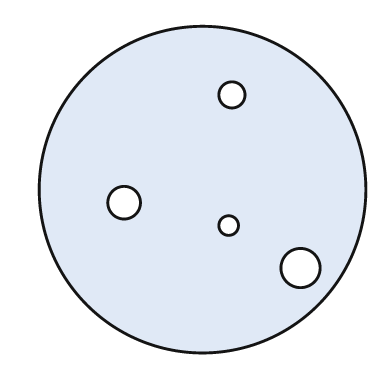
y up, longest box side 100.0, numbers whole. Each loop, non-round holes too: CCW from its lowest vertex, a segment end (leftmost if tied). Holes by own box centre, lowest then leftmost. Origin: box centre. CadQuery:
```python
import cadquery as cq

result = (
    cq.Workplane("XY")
    .moveTo(0.0, 0.0)
    .circle(50.0)
    .moveTo(30.0, -24.0)
    .circle(6.0)
    .moveTo(8.0, -11.0)
    .circle(3.0)
    .moveTo(-24.0, -4.0)
    .circle(5.0)
    .moveTo(9.0, 29.0)
    .circle(4.0)
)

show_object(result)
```